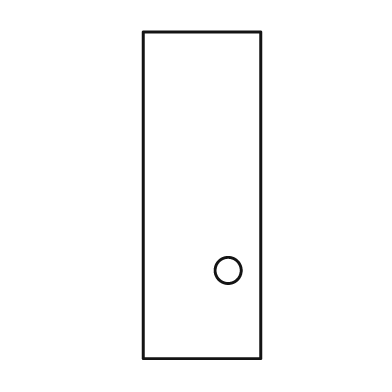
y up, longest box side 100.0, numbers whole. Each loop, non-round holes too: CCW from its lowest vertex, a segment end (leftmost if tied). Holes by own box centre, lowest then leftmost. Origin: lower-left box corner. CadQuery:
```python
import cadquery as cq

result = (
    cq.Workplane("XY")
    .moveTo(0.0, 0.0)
    .lineTo(36.0, 0.0)
    .lineTo(36.0, 100.0)
    .lineTo(0.0, 100.0)
    .close()
    .moveTo(26.0, 27.0)
    .circle(4.0)
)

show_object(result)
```